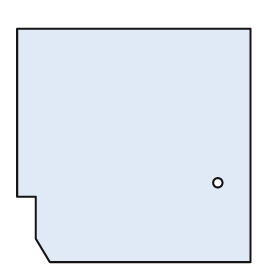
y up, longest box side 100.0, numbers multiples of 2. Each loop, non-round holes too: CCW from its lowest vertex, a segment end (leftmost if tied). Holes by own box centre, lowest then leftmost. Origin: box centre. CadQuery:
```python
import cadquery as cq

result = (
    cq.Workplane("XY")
    .moveTo(-36.0, -50.0)
    .lineTo(50.0, -50.0)
    .lineTo(50.0, 50.0)
    .lineTo(-50.0, 50.0)
    .lineTo(-50.0, -22.0)
    .lineTo(-42.0, -22.0)
    .lineTo(-42.0, -40.0)
    .close()
    .moveTo(36.0, -16.0)
    .circle(2.0)
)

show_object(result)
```